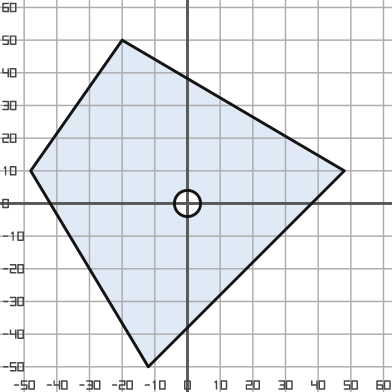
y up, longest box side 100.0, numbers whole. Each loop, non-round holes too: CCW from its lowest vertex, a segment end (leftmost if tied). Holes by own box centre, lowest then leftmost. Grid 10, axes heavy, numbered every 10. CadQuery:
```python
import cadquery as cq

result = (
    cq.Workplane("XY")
    .moveTo(-12.0, -50.0)
    .lineTo(48.0, 10.0)
    .lineTo(-20.0, 50.0)
    .lineTo(-48.0, 10.0)
    .close()
    .moveTo(0.0, 0.0)
    .circle(4.0)
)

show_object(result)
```